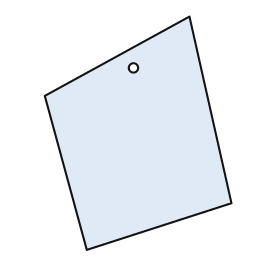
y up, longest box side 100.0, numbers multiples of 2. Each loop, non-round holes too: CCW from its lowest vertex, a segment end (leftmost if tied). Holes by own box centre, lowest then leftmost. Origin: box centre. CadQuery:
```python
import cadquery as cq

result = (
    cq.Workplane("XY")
    .moveTo(-22.0, -50.0)
    .lineTo(40.0, -30.0)
    .lineTo(22.0, 50.0)
    .lineTo(-40.0, 16.0)
    .close()
    .moveTo(-2.0, 28.0)
    .circle(2.0)
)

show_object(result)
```